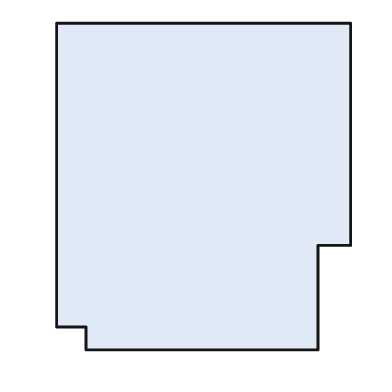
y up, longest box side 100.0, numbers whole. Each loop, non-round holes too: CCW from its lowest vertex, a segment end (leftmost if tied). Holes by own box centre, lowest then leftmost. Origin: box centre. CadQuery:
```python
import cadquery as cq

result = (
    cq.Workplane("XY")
    .moveTo(-36.0, -50.0)
    .lineTo(35.0, -50.0)
    .lineTo(35.0, -18.0)
    .lineTo(45.0, -18.0)
    .lineTo(45.0, 50.0)
    .lineTo(-45.0, 50.0)
    .lineTo(-45.0, -43.0)
    .lineTo(-36.0, -43.0)
    .close()
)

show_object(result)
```